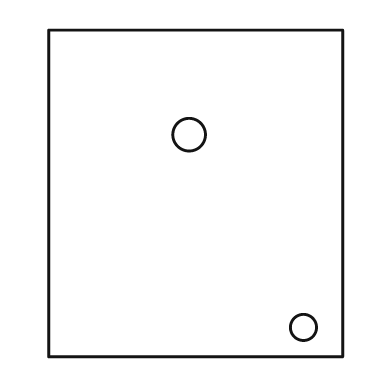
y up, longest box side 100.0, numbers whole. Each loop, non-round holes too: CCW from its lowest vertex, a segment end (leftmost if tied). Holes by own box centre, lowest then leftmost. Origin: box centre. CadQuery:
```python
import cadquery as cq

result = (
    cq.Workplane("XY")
    .moveTo(-45.0, -50.0)
    .lineTo(45.0, -50.0)
    .lineTo(45.0, 50.0)
    .lineTo(-45.0, 50.0)
    .close()
    .moveTo(33.0, -41.0)
    .circle(4.0)
    .moveTo(-2.0, 18.0)
    .circle(5.0)
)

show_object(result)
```